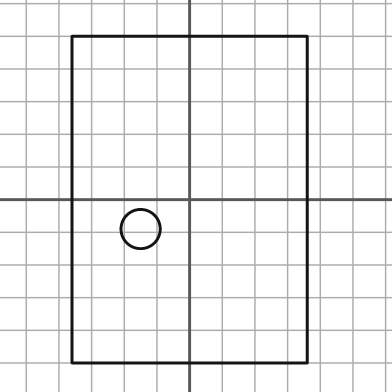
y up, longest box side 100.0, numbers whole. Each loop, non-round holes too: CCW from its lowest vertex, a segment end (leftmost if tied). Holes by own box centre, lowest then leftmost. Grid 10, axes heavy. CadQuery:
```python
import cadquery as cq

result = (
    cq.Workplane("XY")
    .moveTo(-36.0, -50.0)
    .lineTo(36.0, -50.0)
    .lineTo(36.0, 50.0)
    .lineTo(-36.0, 50.0)
    .close()
    .moveTo(-15.0, -9.0)
    .circle(6.0)
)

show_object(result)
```